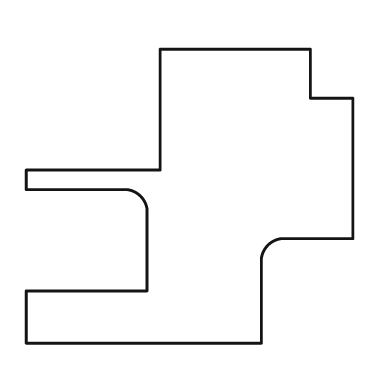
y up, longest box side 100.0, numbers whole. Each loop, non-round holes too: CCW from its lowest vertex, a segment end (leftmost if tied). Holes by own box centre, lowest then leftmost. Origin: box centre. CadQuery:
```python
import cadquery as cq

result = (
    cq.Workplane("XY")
    .moveTo(-50.0, -45.0)
    .lineTo(22.0, -45.0)
    .lineTo(22.0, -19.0)
    .threePointArc((24.0, -15.0), (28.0, -13.0))
    .lineTo(50.0, -13.0)
    .lineTo(50.0, 30.0)
    .lineTo(37.0, 30.0)
    .lineTo(37.0, 45.0)
    .lineTo(-9.0, 45.0)
    .lineTo(-9.0, 8.0)
    .lineTo(-50.0, 8.0)
    .lineTo(-50.0, 2.0)
    .lineTo(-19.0, 2.0)
    .threePointArc((-15.0, 0.0), (-13.0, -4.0))
    .lineTo(-13.0, -29.0)
    .lineTo(-50.0, -29.0)
    .close()
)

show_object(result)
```